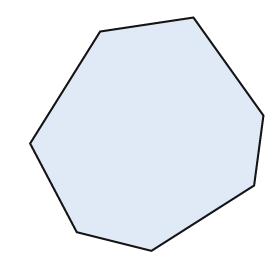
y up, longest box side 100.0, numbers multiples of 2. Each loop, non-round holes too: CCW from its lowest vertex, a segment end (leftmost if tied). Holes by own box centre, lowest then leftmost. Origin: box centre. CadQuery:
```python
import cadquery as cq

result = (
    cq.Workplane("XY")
    .moveTo(2.0, -50.0)
    .lineTo(46.0, -22.0)
    .lineTo(50.0, 8.0)
    .lineTo(20.0, 50.0)
    .lineTo(-20.0, 44.0)
    .lineTo(-50.0, -4.0)
    .lineTo(-30.0, -42.0)
    .close()
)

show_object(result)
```